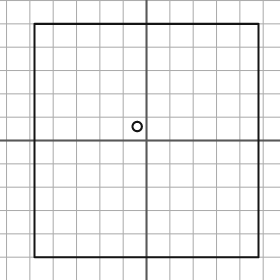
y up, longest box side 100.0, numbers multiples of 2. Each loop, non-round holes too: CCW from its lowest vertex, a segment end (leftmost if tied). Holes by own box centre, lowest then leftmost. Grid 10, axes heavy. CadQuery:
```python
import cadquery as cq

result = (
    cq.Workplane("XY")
    .moveTo(-48.0, -50.0)
    .lineTo(48.0, -50.0)
    .lineTo(48.0, 50.0)
    .lineTo(-48.0, 50.0)
    .close()
    .moveTo(-4.0, 6.0)
    .circle(2.0)
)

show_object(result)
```